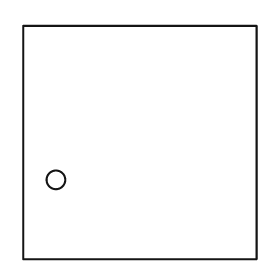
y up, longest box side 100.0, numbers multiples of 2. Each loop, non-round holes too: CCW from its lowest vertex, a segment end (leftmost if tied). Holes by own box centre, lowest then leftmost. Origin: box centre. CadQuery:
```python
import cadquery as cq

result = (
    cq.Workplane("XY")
    .moveTo(-50.0, -50.0)
    .lineTo(50.0, -50.0)
    .lineTo(50.0, 50.0)
    .lineTo(-50.0, 50.0)
    .close()
    .moveTo(-36.0, -16.0)
    .circle(4.0)
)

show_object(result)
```